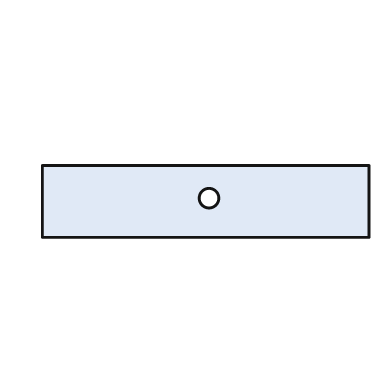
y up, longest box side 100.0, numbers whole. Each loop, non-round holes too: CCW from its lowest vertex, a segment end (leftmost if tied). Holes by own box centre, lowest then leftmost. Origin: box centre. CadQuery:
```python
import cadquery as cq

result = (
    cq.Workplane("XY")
    .moveTo(-50.0, -11.0)
    .lineTo(50.0, -11.0)
    .lineTo(50.0, 11.0)
    .lineTo(-50.0, 11.0)
    .close()
    .moveTo(1.0, 1.0)
    .circle(3.0)
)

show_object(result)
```